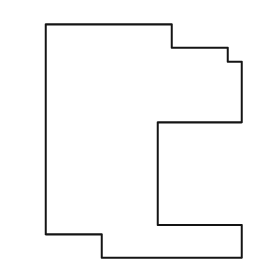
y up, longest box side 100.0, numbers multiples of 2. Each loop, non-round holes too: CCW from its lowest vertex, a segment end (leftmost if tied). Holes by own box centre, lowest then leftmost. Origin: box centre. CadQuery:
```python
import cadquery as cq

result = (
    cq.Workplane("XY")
    .moveTo(-18.0, -50.0)
    .lineTo(42.0, -50.0)
    .lineTo(42.0, -36.0)
    .lineTo(6.0, -36.0)
    .lineTo(6.0, 8.0)
    .lineTo(42.0, 8.0)
    .lineTo(42.0, 34.0)
    .lineTo(36.0, 34.0)
    .lineTo(36.0, 40.0)
    .lineTo(12.0, 40.0)
    .lineTo(12.0, 50.0)
    .lineTo(-42.0, 50.0)
    .lineTo(-42.0, -40.0)
    .lineTo(-18.0, -40.0)
    .close()
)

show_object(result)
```